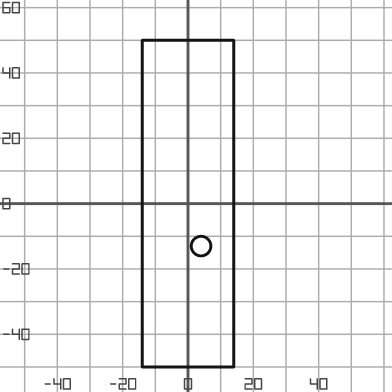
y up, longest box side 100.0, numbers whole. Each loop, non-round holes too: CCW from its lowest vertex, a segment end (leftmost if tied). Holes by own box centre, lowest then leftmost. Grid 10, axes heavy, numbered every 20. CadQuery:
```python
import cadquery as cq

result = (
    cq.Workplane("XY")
    .moveTo(-14.0, -50.0)
    .lineTo(14.0, -50.0)
    .lineTo(14.0, 50.0)
    .lineTo(-14.0, 50.0)
    .close()
    .moveTo(4.0, -13.0)
    .circle(3.0)
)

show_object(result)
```